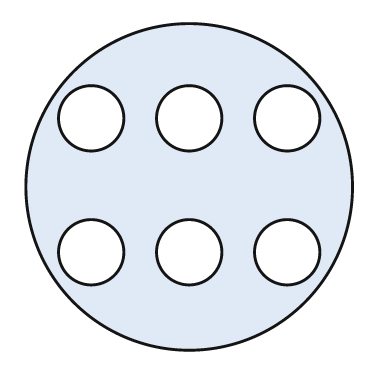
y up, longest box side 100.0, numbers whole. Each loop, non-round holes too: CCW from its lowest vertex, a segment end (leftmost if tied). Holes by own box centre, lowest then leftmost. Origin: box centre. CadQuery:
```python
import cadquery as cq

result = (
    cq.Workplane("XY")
    .moveTo(0.0, 0.0)
    .circle(50.0)
    .moveTo(-30.0, -20.0)
    .circle(10.0)
    .moveTo(0.0, -20.0)
    .circle(10.0)
    .moveTo(30.0, -20.0)
    .circle(10.0)
    .moveTo(-30.0, 21.0)
    .circle(10.0)
    .moveTo(0.0, 21.0)
    .circle(10.0)
    .moveTo(30.0, 21.0)
    .circle(10.0)
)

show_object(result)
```